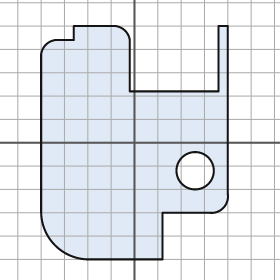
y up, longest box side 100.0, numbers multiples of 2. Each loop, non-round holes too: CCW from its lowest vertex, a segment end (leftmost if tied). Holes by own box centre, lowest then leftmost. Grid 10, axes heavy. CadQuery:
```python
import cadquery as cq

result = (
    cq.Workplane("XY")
    .moveTo(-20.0, -50.0)
    .lineTo(12.0, -50.0)
    .lineTo(12.0, -30.0)
    .lineTo(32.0, -30.0)
    .threePointArc((38.0, -28.0), (40.0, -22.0))
    .lineTo(40.0, 50.0)
    .lineTo(36.0, 50.0)
    .lineTo(36.0, 22.0)
    .lineTo(-2.0, 22.0)
    .lineTo(-2.0, 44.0)
    .threePointArc((-4.0, 48.0), (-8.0, 50.0))
    .lineTo(-26.0, 50.0)
    .lineTo(-26.0, 44.0)
    .lineTo(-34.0, 44.0)
    .threePointArc((-38.0, 42.0), (-40.0, 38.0))
    .lineTo(-40.0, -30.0)
    .threePointArc((-34.0, -44.0), (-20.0, -50.0))
    .close()
    .moveTo(26.0, -12.0)
    .circle(8.0)
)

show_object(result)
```